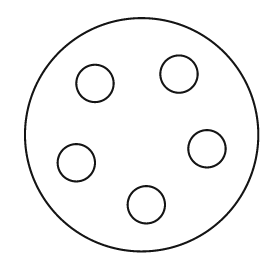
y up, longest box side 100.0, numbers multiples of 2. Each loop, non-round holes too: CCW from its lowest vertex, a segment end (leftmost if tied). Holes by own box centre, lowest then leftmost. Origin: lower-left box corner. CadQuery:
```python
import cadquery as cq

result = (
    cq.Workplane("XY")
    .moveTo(50.0, 50.0)
    .circle(50.0)
    .moveTo(52.0, 20.0)
    .circle(8.0)
    .moveTo(22.0, 38.0)
    .circle(8.0)
    .moveTo(78.0, 44.0)
    .circle(8.0)
    .moveTo(30.0, 72.0)
    .circle(8.0)
    .moveTo(66.0, 76.0)
    .circle(8.0)
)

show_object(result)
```